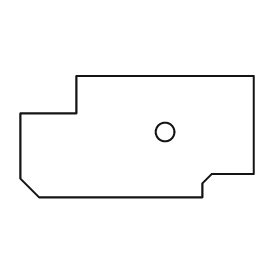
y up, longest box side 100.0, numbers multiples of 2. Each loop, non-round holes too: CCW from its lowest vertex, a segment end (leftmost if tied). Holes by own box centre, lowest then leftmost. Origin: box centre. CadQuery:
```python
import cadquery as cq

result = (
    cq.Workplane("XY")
    .moveTo(-42.0, -26.0)
    .lineTo(28.0, -26.0)
    .lineTo(28.0, -20.0)
    .lineTo(32.0, -16.0)
    .lineTo(50.0, -16.0)
    .lineTo(50.0, 26.0)
    .lineTo(-26.0, 26.0)
    .lineTo(-26.0, 10.0)
    .lineTo(-50.0, 10.0)
    .lineTo(-50.0, -18.0)
    .close()
    .moveTo(12.0, 2.0)
    .circle(4.0)
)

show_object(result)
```